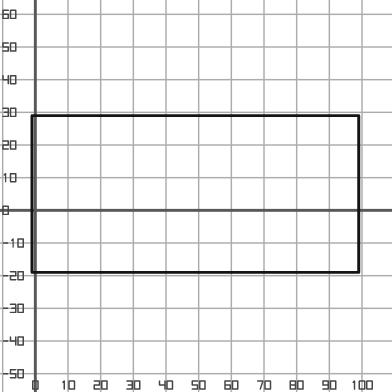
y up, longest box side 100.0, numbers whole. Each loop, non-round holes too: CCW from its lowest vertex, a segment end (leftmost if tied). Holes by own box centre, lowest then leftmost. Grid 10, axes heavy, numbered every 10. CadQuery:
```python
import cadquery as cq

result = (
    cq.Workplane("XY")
    .moveTo(-1.0, -19.0)
    .lineTo(99.0, -19.0)
    .lineTo(99.0, 29.0)
    .lineTo(-1.0, 29.0)
    .close()
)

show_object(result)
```